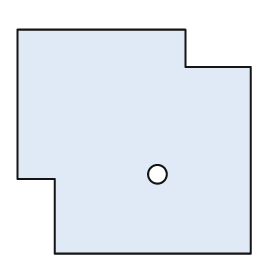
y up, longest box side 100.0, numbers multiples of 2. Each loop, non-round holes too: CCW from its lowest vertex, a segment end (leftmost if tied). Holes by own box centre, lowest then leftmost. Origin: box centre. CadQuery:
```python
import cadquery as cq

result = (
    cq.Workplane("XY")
    .moveTo(-34.0, -48.0)
    .lineTo(50.0, -48.0)
    .lineTo(50.0, 32.0)
    .lineTo(22.0, 32.0)
    .lineTo(22.0, 48.0)
    .lineTo(-50.0, 48.0)
    .lineTo(-50.0, -16.0)
    .lineTo(-34.0, -16.0)
    .close()
    .moveTo(10.0, -14.0)
    .circle(4.0)
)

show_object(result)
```